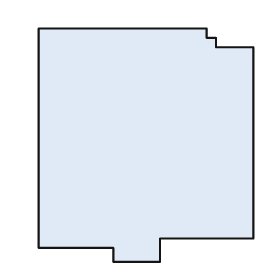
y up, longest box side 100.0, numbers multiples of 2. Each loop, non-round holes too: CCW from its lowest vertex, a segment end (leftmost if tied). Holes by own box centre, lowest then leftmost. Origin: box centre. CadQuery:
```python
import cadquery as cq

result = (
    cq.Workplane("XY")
    .moveTo(-14.0, -50.0)
    .lineTo(6.0, -50.0)
    .lineTo(6.0, -40.0)
    .lineTo(46.0, -40.0)
    .lineTo(46.0, 42.0)
    .lineTo(30.0, 42.0)
    .lineTo(30.0, 46.0)
    .lineTo(26.0, 46.0)
    .lineTo(26.0, 50.0)
    .lineTo(-46.0, 50.0)
    .lineTo(-46.0, -44.0)
    .lineTo(-14.0, -44.0)
    .close()
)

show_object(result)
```